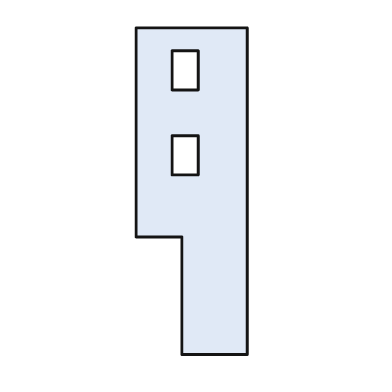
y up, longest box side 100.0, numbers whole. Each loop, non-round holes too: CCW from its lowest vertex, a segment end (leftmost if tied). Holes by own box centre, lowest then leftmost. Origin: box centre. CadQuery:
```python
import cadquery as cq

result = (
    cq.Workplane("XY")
    .moveTo(-3.0, -50.0)
    .lineTo(17.0, -50.0)
    .lineTo(17.0, 50.0)
    .lineTo(-17.0, 50.0)
    .lineTo(-17.0, -14.0)
    .lineTo(-3.0, -14.0)
    .close()
    .moveTo(-6.0, 5.0)
    .lineTo(2.0, 5.0)
    .lineTo(2.0, 17.0)
    .lineTo(-6.0, 17.0)
    .close()
    .moveTo(-6.0, 31.0)
    .lineTo(2.0, 31.0)
    .lineTo(2.0, 43.0)
    .lineTo(-6.0, 43.0)
    .close()
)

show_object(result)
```